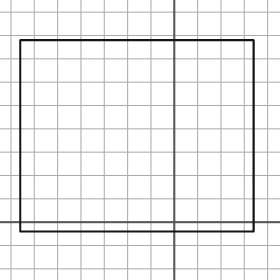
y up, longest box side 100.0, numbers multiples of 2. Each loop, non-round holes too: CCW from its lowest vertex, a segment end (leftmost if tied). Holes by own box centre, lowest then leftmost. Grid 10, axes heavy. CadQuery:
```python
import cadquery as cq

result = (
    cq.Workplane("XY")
    .moveTo(-66.0, -4.0)
    .lineTo(34.0, -4.0)
    .lineTo(34.0, 78.0)
    .lineTo(-66.0, 78.0)
    .close()
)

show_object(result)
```